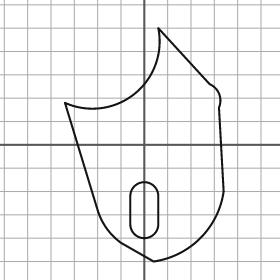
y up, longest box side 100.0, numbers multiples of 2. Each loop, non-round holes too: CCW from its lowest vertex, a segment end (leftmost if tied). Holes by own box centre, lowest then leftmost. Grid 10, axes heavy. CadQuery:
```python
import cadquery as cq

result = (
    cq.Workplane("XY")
    .moveTo(4.0, -50.0)
    .threePointArc((24.0, -40.0), (34.0, -20.0))
    .lineTo(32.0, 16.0)
    .threePointArc((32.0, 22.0), (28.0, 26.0))
    .lineTo(6.0, 50.0)
    .threePointArc((-4.0, 22.0), (-34.0, 18.0))
    .lineTo(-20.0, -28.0)
    .threePointArc((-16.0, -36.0), (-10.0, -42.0))
    .close()
    .moveTo(-6.0, -34.0)
    .threePointArc((0.0, -40.0), (6.0, -34.0))
    .lineTo(6.0, -22.0)
    .threePointArc((0.0, -16.0), (-6.0, -22.0))
    .close()
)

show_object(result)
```